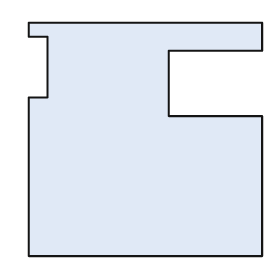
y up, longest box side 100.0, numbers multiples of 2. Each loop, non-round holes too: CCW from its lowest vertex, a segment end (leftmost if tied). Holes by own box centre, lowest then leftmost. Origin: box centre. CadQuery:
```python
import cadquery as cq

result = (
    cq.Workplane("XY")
    .moveTo(-50.0, -50.0)
    .lineTo(50.0, -50.0)
    .lineTo(50.0, 10.0)
    .lineTo(10.0, 10.0)
    .lineTo(10.0, 38.0)
    .lineTo(50.0, 38.0)
    .lineTo(50.0, 50.0)
    .lineTo(-50.0, 50.0)
    .lineTo(-50.0, 44.0)
    .lineTo(-42.0, 44.0)
    .lineTo(-42.0, 18.0)
    .lineTo(-50.0, 18.0)
    .close()
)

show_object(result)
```